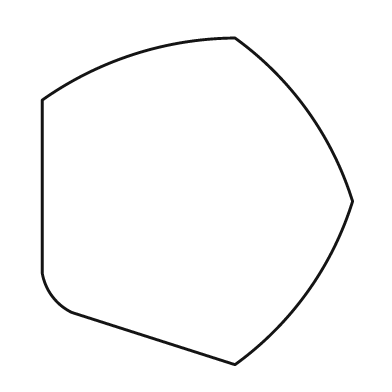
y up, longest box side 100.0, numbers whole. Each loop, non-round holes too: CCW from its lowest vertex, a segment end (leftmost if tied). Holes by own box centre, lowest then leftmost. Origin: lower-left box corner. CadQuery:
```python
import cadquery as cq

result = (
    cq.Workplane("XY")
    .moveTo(59.0, 0.0)
    .threePointArc((81.0, 22.0), (95.0, 50.0))
    .threePointArc((81.0, 78.0), (59.0, 100.0))
    .threePointArc((28.0, 95.0), (0.0, 81.0))
    .lineTo(0.0, 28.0)
    .threePointArc((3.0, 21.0), (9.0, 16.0))
    .close()
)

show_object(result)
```